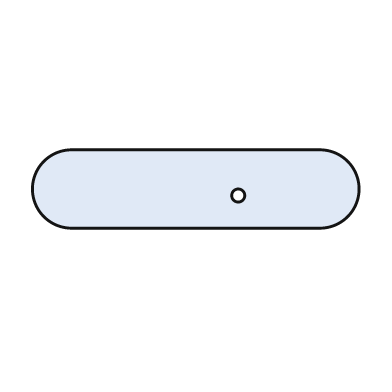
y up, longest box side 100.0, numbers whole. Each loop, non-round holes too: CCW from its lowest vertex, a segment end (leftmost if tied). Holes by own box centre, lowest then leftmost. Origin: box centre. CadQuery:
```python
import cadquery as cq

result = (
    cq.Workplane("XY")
    .moveTo(-38.0, -12.0)
    .lineTo(38.0, -12.0)
    .threePointArc((50.0, 0.0), (38.0, 12.0))
    .lineTo(-38.0, 12.0)
    .threePointArc((-50.0, 0.0), (-38.0, -12.0))
    .close()
    .moveTo(13.0, -2.0)
    .circle(2.0)
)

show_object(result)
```